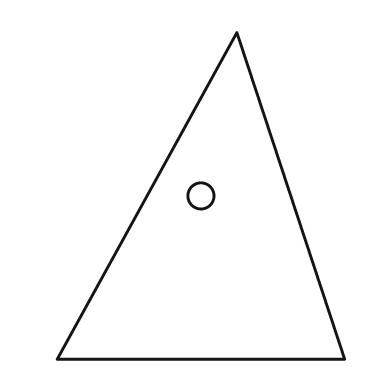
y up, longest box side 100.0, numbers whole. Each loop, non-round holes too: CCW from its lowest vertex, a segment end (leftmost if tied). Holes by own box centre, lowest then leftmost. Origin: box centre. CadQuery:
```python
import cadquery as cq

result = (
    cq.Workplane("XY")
    .moveTo(-44.0, -50.0)
    .lineTo(44.0, -50.0)
    .lineTo(11.0, 50.0)
    .close()
    .moveTo(0.0, 0.0)
    .circle(4.0)
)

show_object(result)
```